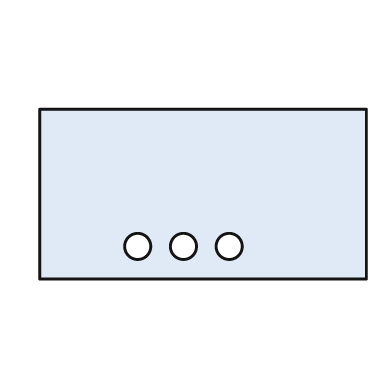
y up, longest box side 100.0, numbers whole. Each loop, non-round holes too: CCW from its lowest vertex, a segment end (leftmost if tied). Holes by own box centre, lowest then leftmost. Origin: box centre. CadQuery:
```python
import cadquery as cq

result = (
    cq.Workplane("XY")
    .moveTo(-50.0, -26.0)
    .lineTo(50.0, -26.0)
    .lineTo(50.0, 26.0)
    .lineTo(-50.0, 26.0)
    .close()
    .moveTo(-20.0, -16.0)
    .circle(4.0)
    .moveTo(-6.0, -16.0)
    .circle(4.0)
    .moveTo(8.0, -16.0)
    .circle(4.0)
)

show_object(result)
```